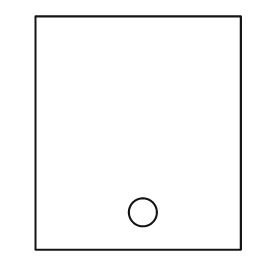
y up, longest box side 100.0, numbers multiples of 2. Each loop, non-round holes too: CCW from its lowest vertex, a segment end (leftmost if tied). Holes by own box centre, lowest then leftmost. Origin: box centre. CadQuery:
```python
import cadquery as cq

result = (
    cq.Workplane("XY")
    .moveTo(-44.0, -50.0)
    .lineTo(44.0, -50.0)
    .lineTo(44.0, 50.0)
    .lineTo(-44.0, 50.0)
    .close()
    .moveTo(2.0, -34.0)
    .circle(6.0)
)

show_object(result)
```